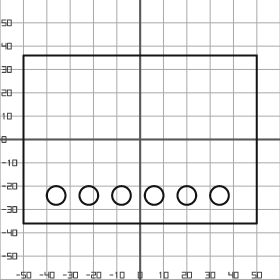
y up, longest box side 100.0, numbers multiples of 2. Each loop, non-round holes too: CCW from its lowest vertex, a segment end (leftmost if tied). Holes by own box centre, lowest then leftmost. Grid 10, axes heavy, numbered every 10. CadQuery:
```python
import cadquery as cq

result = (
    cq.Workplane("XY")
    .moveTo(-50.0, -36.0)
    .lineTo(50.0, -36.0)
    .lineTo(50.0, 36.0)
    .lineTo(-50.0, 36.0)
    .close()
    .moveTo(-36.0, -24.0)
    .circle(4.0)
    .moveTo(-22.0, -24.0)
    .circle(4.0)
    .moveTo(-8.0, -24.0)
    .circle(4.0)
    .moveTo(6.0, -24.0)
    .circle(4.0)
    .moveTo(20.0, -24.0)
    .circle(4.0)
    .moveTo(34.0, -24.0)
    .circle(4.0)
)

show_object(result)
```